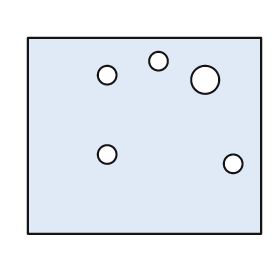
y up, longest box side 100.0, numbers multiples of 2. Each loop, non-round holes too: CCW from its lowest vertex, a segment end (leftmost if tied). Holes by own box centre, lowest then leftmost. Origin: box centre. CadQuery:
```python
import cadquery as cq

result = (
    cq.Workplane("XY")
    .moveTo(-50.0, -42.0)
    .lineTo(50.0, -42.0)
    .lineTo(50.0, 42.0)
    .lineTo(-50.0, 42.0)
    .close()
    .moveTo(38.0, -12.0)
    .circle(4.0)
    .moveTo(-16.0, -8.0)
    .circle(4.0)
    .moveTo(26.0, 24.0)
    .circle(6.0)
    .moveTo(-16.0, 26.0)
    .circle(4.0)
    .moveTo(6.0, 32.0)
    .circle(4.0)
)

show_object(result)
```